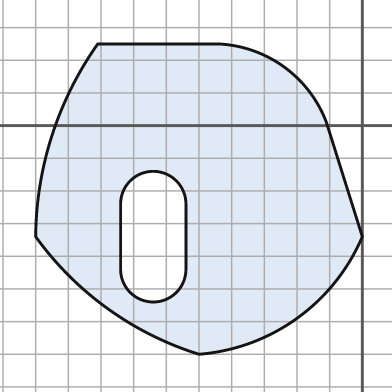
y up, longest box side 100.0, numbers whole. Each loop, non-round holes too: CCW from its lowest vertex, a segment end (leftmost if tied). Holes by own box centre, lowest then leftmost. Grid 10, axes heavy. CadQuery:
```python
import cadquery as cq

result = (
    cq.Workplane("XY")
    .moveTo(-50.0, -70.0)
    .threePointArc((-20.0, -59.0), (0.0, -34.0))
    .lineTo(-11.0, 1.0)
    .threePointArc((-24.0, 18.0), (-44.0, 25.0))
    .lineTo(-81.0, 25.0)
    .threePointArc((-95.0, -3.0), (-100.0, -34.0))
    .threePointArc((-78.0, -56.0), (-50.0, -70.0))
    .close()
    .moveTo(-74.0, -44.0)
    .threePointArc((-64.0, -54.0), (-54.0, -44.0))
    .lineTo(-54.0, -24.0)
    .threePointArc((-64.0, -14.0), (-74.0, -24.0))
    .close()
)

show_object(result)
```